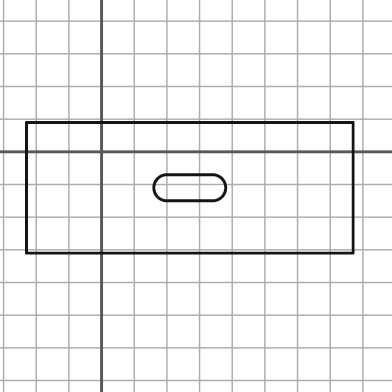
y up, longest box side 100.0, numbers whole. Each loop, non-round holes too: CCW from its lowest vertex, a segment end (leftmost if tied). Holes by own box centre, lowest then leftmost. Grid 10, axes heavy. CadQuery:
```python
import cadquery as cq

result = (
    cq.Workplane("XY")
    .moveTo(-23.0, -31.0)
    .lineTo(77.0, -31.0)
    .lineTo(77.0, 9.0)
    .lineTo(-23.0, 9.0)
    .close()
    .moveTo(20.0, -15.0)
    .lineTo(34.0, -15.0)
    .threePointArc((38.0, -11.0), (34.0, -7.0))
    .lineTo(20.0, -7.0)
    .threePointArc((16.0, -11.0), (20.0, -15.0))
    .close()
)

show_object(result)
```